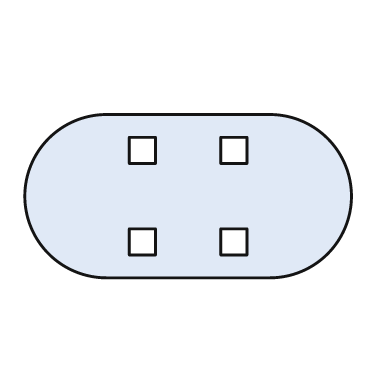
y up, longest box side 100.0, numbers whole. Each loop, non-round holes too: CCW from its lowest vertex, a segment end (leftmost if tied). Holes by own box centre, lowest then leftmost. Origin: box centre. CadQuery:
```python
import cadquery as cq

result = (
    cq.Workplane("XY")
    .moveTo(-25.0, -25.0)
    .lineTo(25.0, -25.0)
    .threePointArc((50.0, 0.0), (25.0, 25.0))
    .lineTo(-25.0, 25.0)
    .threePointArc((-50.0, 0.0), (-25.0, -25.0))
    .close()
    .moveTo(-18.0, -18.0)
    .lineTo(-10.0, -18.0)
    .lineTo(-10.0, -10.0)
    .lineTo(-18.0, -10.0)
    .close()
    .moveTo(10.0, -18.0)
    .lineTo(18.0, -18.0)
    .lineTo(18.0, -10.0)
    .lineTo(10.0, -10.0)
    .close()
    .moveTo(-18.0, 10.0)
    .lineTo(-10.0, 10.0)
    .lineTo(-10.0, 18.0)
    .lineTo(-18.0, 18.0)
    .close()
    .moveTo(10.0, 10.0)
    .lineTo(18.0, 10.0)
    .lineTo(18.0, 18.0)
    .lineTo(10.0, 18.0)
    .close()
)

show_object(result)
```